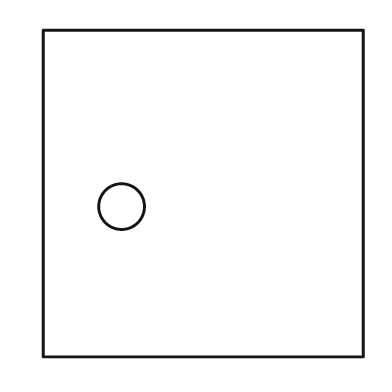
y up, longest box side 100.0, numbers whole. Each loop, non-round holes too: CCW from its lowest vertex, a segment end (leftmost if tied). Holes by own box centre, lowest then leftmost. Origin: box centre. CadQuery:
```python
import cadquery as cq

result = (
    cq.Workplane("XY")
    .moveTo(-49.0, -50.0)
    .lineTo(49.0, -50.0)
    .lineTo(49.0, 50.0)
    .lineTo(-49.0, 50.0)
    .close()
    .moveTo(-25.0, -4.0)
    .circle(7.0)
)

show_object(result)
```